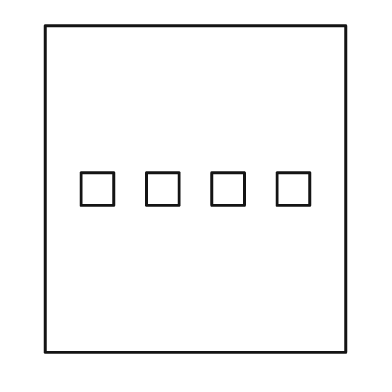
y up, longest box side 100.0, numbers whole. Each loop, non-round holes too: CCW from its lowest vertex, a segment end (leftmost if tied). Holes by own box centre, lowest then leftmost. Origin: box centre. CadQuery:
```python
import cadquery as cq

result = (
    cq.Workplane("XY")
    .moveTo(-46.0, -50.0)
    .lineTo(46.0, -50.0)
    .lineTo(46.0, 50.0)
    .lineTo(-46.0, 50.0)
    .close()
    .moveTo(-35.0, -5.0)
    .lineTo(-25.0, -5.0)
    .lineTo(-25.0, 5.0)
    .lineTo(-35.0, 5.0)
    .close()
    .moveTo(-15.0, -5.0)
    .lineTo(-5.0, -5.0)
    .lineTo(-5.0, 5.0)
    .lineTo(-15.0, 5.0)
    .close()
    .moveTo(5.0, -5.0)
    .lineTo(15.0, -5.0)
    .lineTo(15.0, 5.0)
    .lineTo(5.0, 5.0)
    .close()
    .moveTo(25.0, -5.0)
    .lineTo(35.0, -5.0)
    .lineTo(35.0, 5.0)
    .lineTo(25.0, 5.0)
    .close()
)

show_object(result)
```